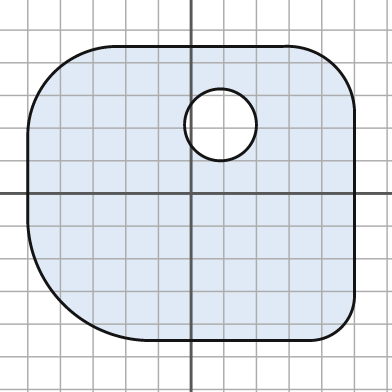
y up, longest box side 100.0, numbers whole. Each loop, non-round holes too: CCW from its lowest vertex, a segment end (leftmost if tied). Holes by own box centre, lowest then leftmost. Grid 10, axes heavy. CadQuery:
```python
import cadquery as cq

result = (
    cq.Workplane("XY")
    .moveTo(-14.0, -45.0)
    .lineTo(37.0, -45.0)
    .threePointArc((46.0, -41.0), (50.0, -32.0))
    .lineTo(50.0, 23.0)
    .threePointArc((44.0, 39.0), (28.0, 45.0))
    .lineTo(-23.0, 45.0)
    .threePointArc((-42.0, 37.0), (-50.0, 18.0))
    .lineTo(-50.0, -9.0)
    .threePointArc((-39.0, -34.0), (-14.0, -45.0))
    .close()
    .moveTo(9.0, 21.0)
    .circle(11.0)
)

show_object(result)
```